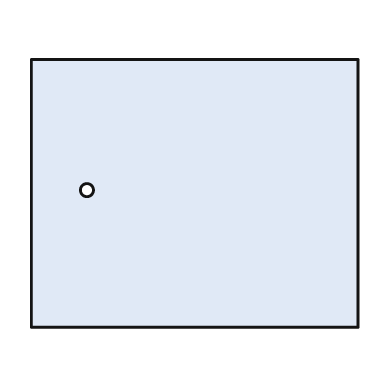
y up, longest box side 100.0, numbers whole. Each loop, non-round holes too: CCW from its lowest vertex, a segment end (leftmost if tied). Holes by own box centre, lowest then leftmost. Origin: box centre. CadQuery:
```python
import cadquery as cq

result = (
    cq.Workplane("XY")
    .moveTo(-50.0, -41.0)
    .lineTo(50.0, -41.0)
    .lineTo(50.0, 41.0)
    .lineTo(-50.0, 41.0)
    .close()
    .moveTo(-33.0, 1.0)
    .circle(2.0)
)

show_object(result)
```